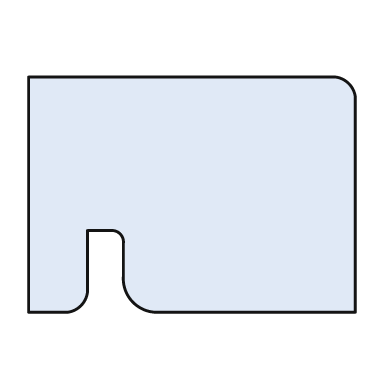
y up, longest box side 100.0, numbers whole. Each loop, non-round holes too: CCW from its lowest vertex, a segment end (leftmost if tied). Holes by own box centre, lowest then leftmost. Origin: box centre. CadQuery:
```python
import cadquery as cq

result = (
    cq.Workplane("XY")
    .moveTo(-50.0, -36.0)
    .lineTo(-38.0, -36.0)
    .threePointArc((-34.0, -34.0), (-32.0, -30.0))
    .lineTo(-32.0, -11.0)
    .lineTo(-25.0, -11.0)
    .threePointArc((-22.0, -12.0), (-21.0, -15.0))
    .lineTo(-21.0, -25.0)
    .threePointArc((-18.0, -33.0), (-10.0, -36.0))
    .lineTo(50.0, -36.0)
    .lineTo(50.0, 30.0)
    .threePointArc((48.0, 34.0), (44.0, 36.0))
    .lineTo(-50.0, 36.0)
    .close()
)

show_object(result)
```